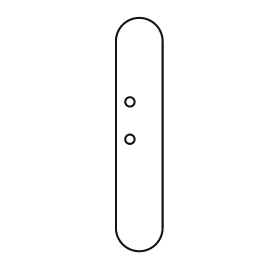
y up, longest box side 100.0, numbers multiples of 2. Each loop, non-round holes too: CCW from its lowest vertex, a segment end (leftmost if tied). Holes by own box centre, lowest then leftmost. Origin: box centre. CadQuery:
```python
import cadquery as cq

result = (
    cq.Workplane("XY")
    .moveTo(-10.0, -40.0)
    .threePointArc((0.0, -50.0), (10.0, -40.0))
    .lineTo(10.0, 40.0)
    .threePointArc((0.0, 50.0), (-10.0, 40.0))
    .close()
    .moveTo(-4.0, -2.0)
    .circle(2.0)
    .moveTo(-4.0, 14.0)
    .circle(2.0)
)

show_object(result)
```